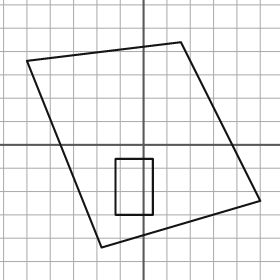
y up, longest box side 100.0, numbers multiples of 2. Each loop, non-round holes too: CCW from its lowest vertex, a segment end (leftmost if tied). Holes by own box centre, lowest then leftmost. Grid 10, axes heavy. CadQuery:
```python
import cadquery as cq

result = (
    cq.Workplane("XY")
    .moveTo(-18.0, -44.0)
    .lineTo(50.0, -24.0)
    .lineTo(16.0, 44.0)
    .lineTo(-50.0, 36.0)
    .close()
    .moveTo(-12.0, -30.0)
    .lineTo(4.0, -30.0)
    .lineTo(4.0, -6.0)
    .lineTo(-12.0, -6.0)
    .close()
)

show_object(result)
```